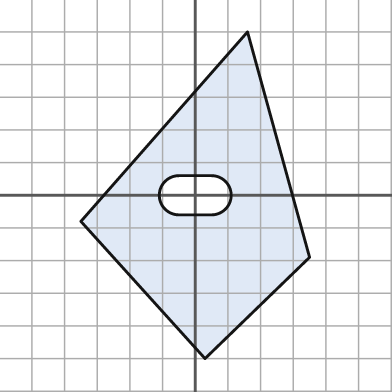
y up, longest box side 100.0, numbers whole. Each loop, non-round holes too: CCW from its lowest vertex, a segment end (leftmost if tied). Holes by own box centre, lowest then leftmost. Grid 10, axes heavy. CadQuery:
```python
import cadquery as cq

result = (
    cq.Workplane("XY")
    .moveTo(3.0, -50.0)
    .lineTo(35.0, -19.0)
    .lineTo(16.0, 50.0)
    .lineTo(-35.0, -8.0)
    .close()
    .moveTo(-5.0, -6.0)
    .lineTo(5.0, -6.0)
    .threePointArc((11.0, 0.0), (5.0, 6.0))
    .lineTo(-5.0, 6.0)
    .threePointArc((-11.0, 0.0), (-5.0, -6.0))
    .close()
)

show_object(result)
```